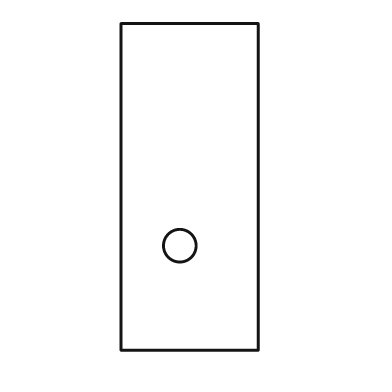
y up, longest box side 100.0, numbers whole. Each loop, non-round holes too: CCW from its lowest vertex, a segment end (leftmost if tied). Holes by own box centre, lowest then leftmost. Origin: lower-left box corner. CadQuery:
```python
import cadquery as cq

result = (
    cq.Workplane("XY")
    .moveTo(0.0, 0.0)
    .lineTo(42.0, 0.0)
    .lineTo(42.0, 100.0)
    .lineTo(0.0, 100.0)
    .close()
    .moveTo(18.0, 32.0)
    .circle(5.0)
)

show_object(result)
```